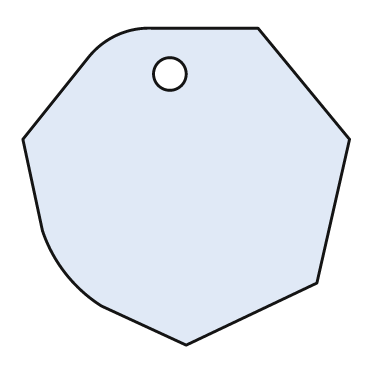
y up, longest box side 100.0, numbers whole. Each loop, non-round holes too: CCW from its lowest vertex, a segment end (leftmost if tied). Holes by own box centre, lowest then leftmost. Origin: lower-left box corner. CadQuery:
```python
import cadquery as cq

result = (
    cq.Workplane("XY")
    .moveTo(50.0, 0.0)
    .lineTo(90.0, 19.0)
    .lineTo(100.0, 63.0)
    .lineTo(72.0, 97.0)
    .lineTo(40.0, 97.0)
    .threePointArc((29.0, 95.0), (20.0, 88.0))
    .lineTo(0.0, 63.0)
    .lineTo(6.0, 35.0)
    .threePointArc((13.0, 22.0), (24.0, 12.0))
    .close()
    .moveTo(45.0, 83.0)
    .circle(5.0)
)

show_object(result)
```